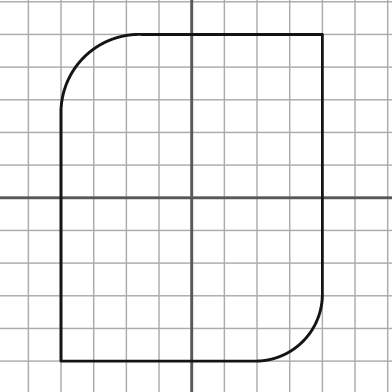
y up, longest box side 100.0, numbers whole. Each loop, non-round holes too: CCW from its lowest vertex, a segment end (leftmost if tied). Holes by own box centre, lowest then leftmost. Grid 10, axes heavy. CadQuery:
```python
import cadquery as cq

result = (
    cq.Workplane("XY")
    .moveTo(-40.0, -50.0)
    .lineTo(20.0, -50.0)
    .threePointArc((34.0, -44.0), (40.0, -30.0))
    .lineTo(40.0, 50.0)
    .lineTo(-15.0, 50.0)
    .threePointArc((-33.0, 43.0), (-40.0, 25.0))
    .close()
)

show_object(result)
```